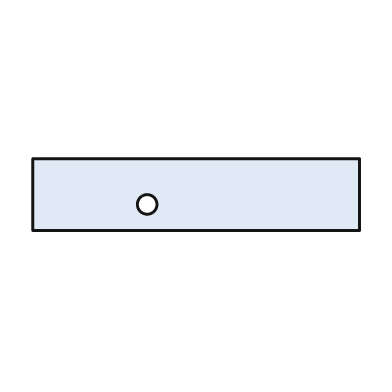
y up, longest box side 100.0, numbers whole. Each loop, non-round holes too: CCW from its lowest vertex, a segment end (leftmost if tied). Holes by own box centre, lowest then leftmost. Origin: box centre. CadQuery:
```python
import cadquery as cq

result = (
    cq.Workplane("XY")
    .moveTo(-50.0, -11.0)
    .lineTo(50.0, -11.0)
    .lineTo(50.0, 11.0)
    .lineTo(-50.0, 11.0)
    .close()
    .moveTo(-15.0, -3.0)
    .circle(3.0)
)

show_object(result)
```